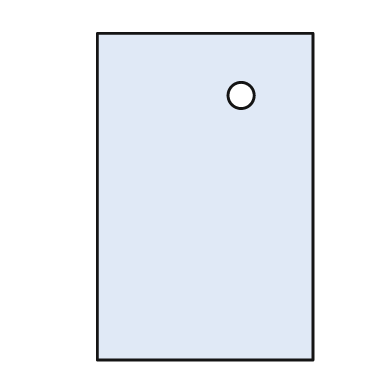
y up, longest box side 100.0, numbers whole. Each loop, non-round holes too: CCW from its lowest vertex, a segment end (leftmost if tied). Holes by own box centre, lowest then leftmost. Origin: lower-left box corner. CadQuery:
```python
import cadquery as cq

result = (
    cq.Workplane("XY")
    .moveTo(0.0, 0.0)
    .lineTo(66.0, 0.0)
    .lineTo(66.0, 100.0)
    .lineTo(0.0, 100.0)
    .close()
    .moveTo(44.0, 81.0)
    .circle(4.0)
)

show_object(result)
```